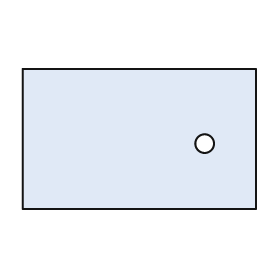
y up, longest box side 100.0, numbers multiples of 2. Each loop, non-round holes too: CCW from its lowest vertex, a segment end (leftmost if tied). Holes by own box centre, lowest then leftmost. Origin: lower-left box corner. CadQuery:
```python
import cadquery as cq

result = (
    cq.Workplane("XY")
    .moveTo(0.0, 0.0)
    .lineTo(100.0, 0.0)
    .lineTo(100.0, 60.0)
    .lineTo(0.0, 60.0)
    .close()
    .moveTo(78.0, 28.0)
    .circle(4.0)
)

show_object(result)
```